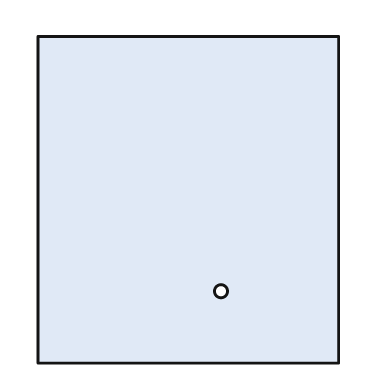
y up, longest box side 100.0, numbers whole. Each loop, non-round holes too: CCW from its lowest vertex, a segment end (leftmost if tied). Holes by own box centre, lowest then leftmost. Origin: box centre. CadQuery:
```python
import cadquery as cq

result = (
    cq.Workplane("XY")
    .moveTo(-46.0, -50.0)
    .lineTo(46.0, -50.0)
    .lineTo(46.0, 50.0)
    .lineTo(-46.0, 50.0)
    .close()
    .moveTo(10.0, -28.0)
    .circle(2.0)
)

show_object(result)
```